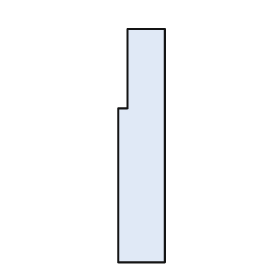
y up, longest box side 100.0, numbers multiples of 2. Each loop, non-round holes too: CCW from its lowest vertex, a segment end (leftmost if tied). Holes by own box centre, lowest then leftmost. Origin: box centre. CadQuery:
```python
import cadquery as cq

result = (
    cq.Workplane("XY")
    .moveTo(-10.0, -50.0)
    .lineTo(10.0, -50.0)
    .lineTo(10.0, 50.0)
    .lineTo(-6.0, 50.0)
    .lineTo(-6.0, 16.0)
    .lineTo(-10.0, 16.0)
    .close()
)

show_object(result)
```